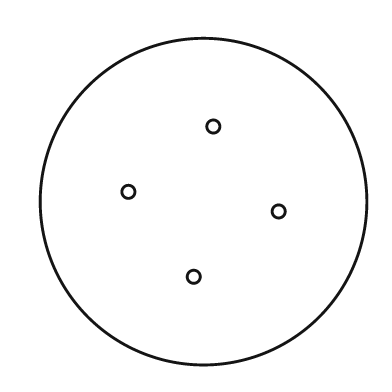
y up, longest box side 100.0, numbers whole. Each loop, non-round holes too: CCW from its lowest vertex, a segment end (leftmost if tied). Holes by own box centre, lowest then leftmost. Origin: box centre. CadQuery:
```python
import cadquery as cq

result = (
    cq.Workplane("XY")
    .moveTo(0.0, 0.0)
    .circle(50.0)
    .moveTo(-3.0, -23.0)
    .circle(2.0)
    .moveTo(23.0, -3.0)
    .circle(2.0)
    .moveTo(-23.0, 3.0)
    .circle(2.0)
    .moveTo(3.0, 23.0)
    .circle(2.0)
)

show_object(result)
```